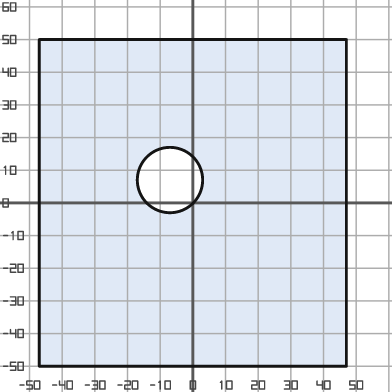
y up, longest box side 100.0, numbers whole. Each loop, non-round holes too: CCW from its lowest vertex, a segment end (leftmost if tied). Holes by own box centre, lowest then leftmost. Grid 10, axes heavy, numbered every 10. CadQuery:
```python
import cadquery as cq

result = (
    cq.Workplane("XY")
    .moveTo(-47.0, -50.0)
    .lineTo(47.0, -50.0)
    .lineTo(47.0, 50.0)
    .lineTo(-47.0, 50.0)
    .close()
    .moveTo(-7.0, 7.0)
    .circle(10.0)
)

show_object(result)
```